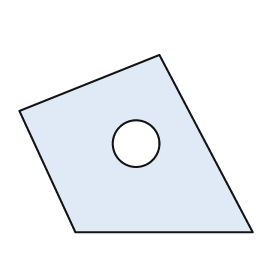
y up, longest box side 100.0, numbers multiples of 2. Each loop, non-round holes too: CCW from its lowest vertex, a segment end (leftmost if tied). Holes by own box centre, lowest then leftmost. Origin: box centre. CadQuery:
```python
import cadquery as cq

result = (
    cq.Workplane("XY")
    .moveTo(-26.0, -38.0)
    .lineTo(50.0, -38.0)
    .lineTo(10.0, 38.0)
    .lineTo(-50.0, 14.0)
    .close()
    .moveTo(0.0, 0.0)
    .circle(10.0)
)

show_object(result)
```